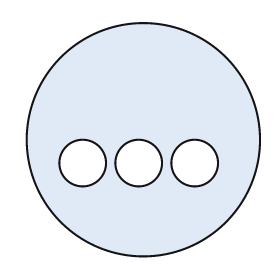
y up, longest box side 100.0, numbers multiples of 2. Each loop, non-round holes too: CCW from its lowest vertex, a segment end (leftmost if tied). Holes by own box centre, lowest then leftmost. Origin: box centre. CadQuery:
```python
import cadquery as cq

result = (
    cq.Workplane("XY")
    .moveTo(0.0, 0.0)
    .circle(50.0)
    .moveTo(-26.0, -10.0)
    .circle(10.0)
    .moveTo(-2.0, -10.0)
    .circle(10.0)
    .moveTo(22.0, -10.0)
    .circle(10.0)
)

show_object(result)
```